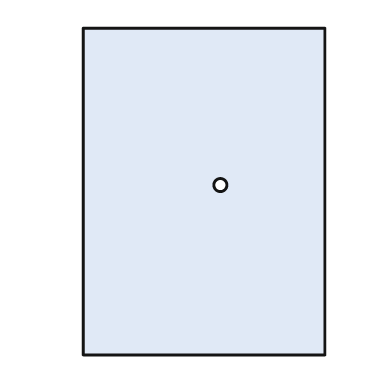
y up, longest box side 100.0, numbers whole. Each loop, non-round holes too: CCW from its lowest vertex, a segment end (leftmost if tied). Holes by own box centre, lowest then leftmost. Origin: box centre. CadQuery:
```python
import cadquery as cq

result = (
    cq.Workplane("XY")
    .moveTo(-37.0, -50.0)
    .lineTo(37.0, -50.0)
    .lineTo(37.0, 50.0)
    .lineTo(-37.0, 50.0)
    .close()
    .moveTo(5.0, 2.0)
    .circle(2.0)
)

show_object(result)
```